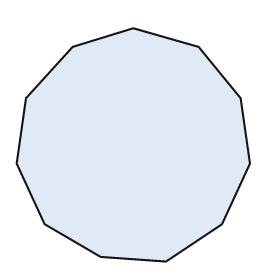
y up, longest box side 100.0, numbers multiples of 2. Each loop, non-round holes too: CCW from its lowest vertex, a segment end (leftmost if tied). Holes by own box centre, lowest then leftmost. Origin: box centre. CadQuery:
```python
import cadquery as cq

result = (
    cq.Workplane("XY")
    .moveTo(14.0, -50.0)
    .lineTo(38.0, -34.0)
    .lineTo(50.0, -8.0)
    .lineTo(46.0, 20.0)
    .lineTo(28.0, 42.0)
    .lineTo(0.0, 50.0)
    .lineTo(-26.0, 42.0)
    .lineTo(-46.0, 20.0)
    .lineTo(-50.0, -8.0)
    .lineTo(-38.0, -34.0)
    .lineTo(-14.0, -48.0)
    .close()
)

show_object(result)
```